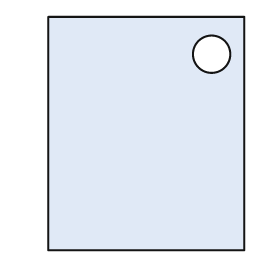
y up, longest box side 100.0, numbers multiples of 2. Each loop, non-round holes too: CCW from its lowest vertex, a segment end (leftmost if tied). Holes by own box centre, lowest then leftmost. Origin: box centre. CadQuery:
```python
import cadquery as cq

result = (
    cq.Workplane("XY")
    .moveTo(-42.0, -50.0)
    .lineTo(42.0, -50.0)
    .lineTo(42.0, 50.0)
    .lineTo(-42.0, 50.0)
    .close()
    .moveTo(28.0, 34.0)
    .circle(8.0)
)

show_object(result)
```